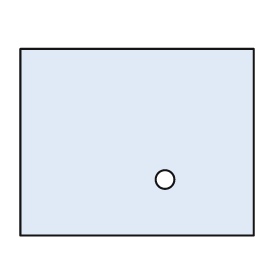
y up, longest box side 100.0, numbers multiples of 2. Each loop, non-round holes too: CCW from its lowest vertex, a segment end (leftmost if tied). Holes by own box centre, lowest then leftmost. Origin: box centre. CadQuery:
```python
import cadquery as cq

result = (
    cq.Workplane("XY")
    .moveTo(-50.0, -40.0)
    .lineTo(50.0, -40.0)
    .lineTo(50.0, 40.0)
    .lineTo(-50.0, 40.0)
    .close()
    .moveTo(12.0, -16.0)
    .circle(4.0)
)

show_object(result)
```